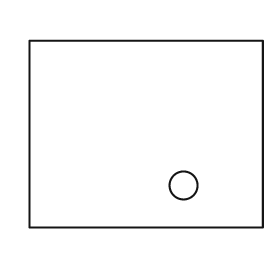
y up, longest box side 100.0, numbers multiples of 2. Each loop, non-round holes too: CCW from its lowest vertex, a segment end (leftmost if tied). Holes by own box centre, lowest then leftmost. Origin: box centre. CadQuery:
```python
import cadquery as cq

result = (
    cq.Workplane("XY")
    .moveTo(-50.0, -40.0)
    .lineTo(50.0, -40.0)
    .lineTo(50.0, 40.0)
    .lineTo(-50.0, 40.0)
    .close()
    .moveTo(16.0, -22.0)
    .circle(6.0)
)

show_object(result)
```